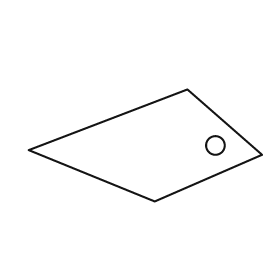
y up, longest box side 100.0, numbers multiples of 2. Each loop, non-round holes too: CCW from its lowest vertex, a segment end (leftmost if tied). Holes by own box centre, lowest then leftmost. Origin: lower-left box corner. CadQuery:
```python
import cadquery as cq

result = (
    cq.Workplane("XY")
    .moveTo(54.0, 0.0)
    .lineTo(100.0, 20.0)
    .lineTo(68.0, 48.0)
    .lineTo(0.0, 22.0)
    .close()
    .moveTo(80.0, 24.0)
    .circle(4.0)
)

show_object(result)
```